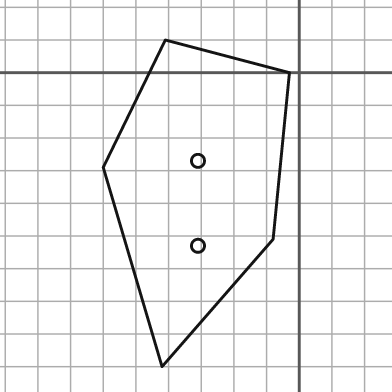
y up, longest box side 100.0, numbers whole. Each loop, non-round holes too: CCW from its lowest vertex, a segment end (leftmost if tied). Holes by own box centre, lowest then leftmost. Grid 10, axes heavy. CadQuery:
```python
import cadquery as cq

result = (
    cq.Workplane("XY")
    .moveTo(-42.0, -90.0)
    .lineTo(-8.0, -51.0)
    .lineTo(-3.0, 0.0)
    .lineTo(-41.0, 10.0)
    .lineTo(-60.0, -29.0)
    .close()
    .moveTo(-31.0, -53.0)
    .circle(2.0)
    .moveTo(-31.0, -27.0)
    .circle(2.0)
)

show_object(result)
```